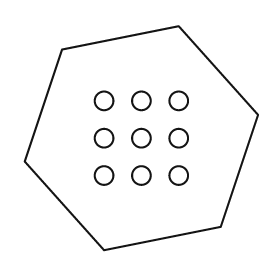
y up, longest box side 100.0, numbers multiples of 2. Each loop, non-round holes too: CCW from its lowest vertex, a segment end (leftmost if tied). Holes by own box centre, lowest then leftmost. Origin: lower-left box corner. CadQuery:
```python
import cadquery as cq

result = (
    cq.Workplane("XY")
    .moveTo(34.0, 0.0)
    .lineTo(84.0, 10.0)
    .lineTo(100.0, 58.0)
    .lineTo(66.0, 96.0)
    .lineTo(16.0, 86.0)
    .lineTo(0.0, 38.0)
    .close()
    .moveTo(34.0, 32.0)
    .circle(4.0)
    .moveTo(50.0, 32.0)
    .circle(4.0)
    .moveTo(66.0, 32.0)
    .circle(4.0)
    .moveTo(34.0, 48.0)
    .circle(4.0)
    .moveTo(50.0, 48.0)
    .circle(4.0)
    .moveTo(66.0, 48.0)
    .circle(4.0)
    .moveTo(34.0, 64.0)
    .circle(4.0)
    .moveTo(50.0, 64.0)
    .circle(4.0)
    .moveTo(66.0, 64.0)
    .circle(4.0)
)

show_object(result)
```